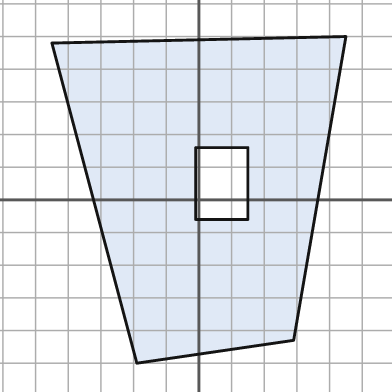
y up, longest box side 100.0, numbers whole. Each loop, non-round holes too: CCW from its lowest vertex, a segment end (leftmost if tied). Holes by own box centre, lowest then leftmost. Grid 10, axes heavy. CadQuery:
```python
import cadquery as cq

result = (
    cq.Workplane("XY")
    .moveTo(-19.0, -50.0)
    .lineTo(29.0, -43.0)
    .lineTo(45.0, 50.0)
    .lineTo(-45.0, 48.0)
    .close()
    .moveTo(-1.0, -6.0)
    .lineTo(15.0, -6.0)
    .lineTo(15.0, 16.0)
    .lineTo(-1.0, 16.0)
    .close()
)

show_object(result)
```